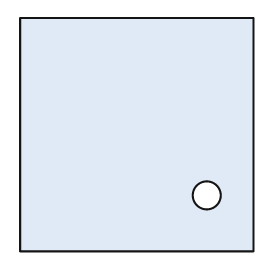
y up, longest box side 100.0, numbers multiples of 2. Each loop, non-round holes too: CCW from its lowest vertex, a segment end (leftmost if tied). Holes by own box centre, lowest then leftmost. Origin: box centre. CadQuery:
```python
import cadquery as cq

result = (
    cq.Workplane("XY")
    .moveTo(-50.0, -50.0)
    .lineTo(50.0, -50.0)
    .lineTo(50.0, 50.0)
    .lineTo(-50.0, 50.0)
    .close()
    .moveTo(30.0, -26.0)
    .circle(6.0)
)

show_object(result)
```